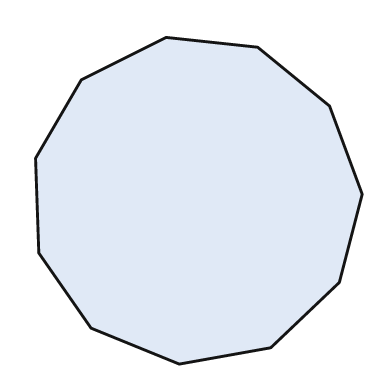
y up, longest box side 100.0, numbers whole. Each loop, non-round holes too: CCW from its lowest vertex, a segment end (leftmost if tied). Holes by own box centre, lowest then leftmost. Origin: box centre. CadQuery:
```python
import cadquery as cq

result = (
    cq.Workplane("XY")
    .moveTo(-6.0, -50.0)
    .lineTo(22.0, -45.0)
    .lineTo(43.0, -25.0)
    .lineTo(50.0, 2.0)
    .lineTo(40.0, 29.0)
    .lineTo(18.0, 47.0)
    .lineTo(-10.0, 50.0)
    .lineTo(-36.0, 37.0)
    .lineTo(-50.0, 13.0)
    .lineTo(-49.0, -16.0)
    .lineTo(-33.0, -39.0)
    .close()
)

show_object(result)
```